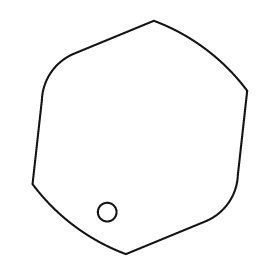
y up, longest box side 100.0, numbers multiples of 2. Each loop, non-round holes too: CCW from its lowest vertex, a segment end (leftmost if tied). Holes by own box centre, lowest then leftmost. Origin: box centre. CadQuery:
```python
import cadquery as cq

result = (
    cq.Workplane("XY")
    .moveTo(-6.0, -50.0)
    .lineTo(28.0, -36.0)
    .threePointArc((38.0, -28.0), (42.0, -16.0))
    .lineTo(46.0, 20.0)
    .threePointArc((28.0, 38.0), (6.0, 50.0))
    .lineTo(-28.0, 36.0)
    .threePointArc((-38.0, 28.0), (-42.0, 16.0))
    .lineTo(-46.0, -20.0)
    .threePointArc((-28.0, -38.0), (-6.0, -50.0))
    .close()
    .moveTo(-14.0, -32.0)
    .circle(4.0)
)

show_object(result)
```